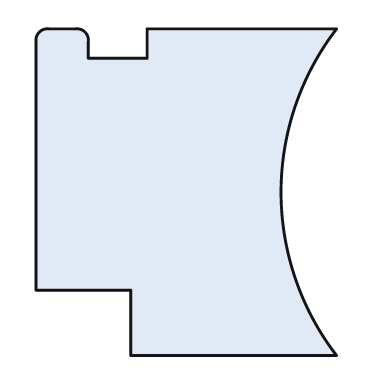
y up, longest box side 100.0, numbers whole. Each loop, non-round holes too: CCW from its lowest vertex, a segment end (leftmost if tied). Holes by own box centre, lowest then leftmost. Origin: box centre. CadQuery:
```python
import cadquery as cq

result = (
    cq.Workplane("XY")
    .moveTo(-17.0, -50.0)
    .lineTo(46.0, -50.0)
    .threePointArc((29.0, 0.0), (46.0, 50.0))
    .lineTo(-12.0, 50.0)
    .lineTo(-12.0, 41.0)
    .lineTo(-30.0, 41.0)
    .lineTo(-30.0, 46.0)
    .threePointArc((-31.0, 49.0), (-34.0, 50.0))
    .lineTo(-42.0, 50.0)
    .threePointArc((-45.0, 49.0), (-46.0, 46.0))
    .lineTo(-46.0, -30.0)
    .lineTo(-17.0, -30.0)
    .close()
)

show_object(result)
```